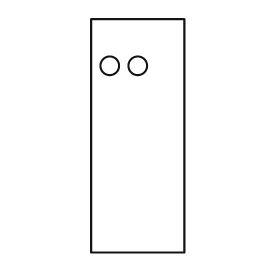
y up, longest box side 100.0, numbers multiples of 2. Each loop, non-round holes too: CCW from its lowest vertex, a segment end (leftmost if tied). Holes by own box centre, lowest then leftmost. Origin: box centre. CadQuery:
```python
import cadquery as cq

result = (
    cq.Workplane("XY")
    .moveTo(-20.0, -50.0)
    .lineTo(20.0, -50.0)
    .lineTo(20.0, 50.0)
    .lineTo(-20.0, 50.0)
    .close()
    .moveTo(-12.0, 30.0)
    .circle(4.0)
    .moveTo(0.0, 30.0)
    .circle(4.0)
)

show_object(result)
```